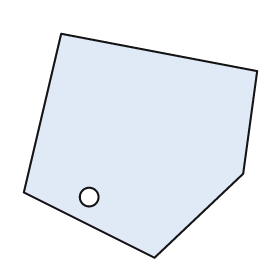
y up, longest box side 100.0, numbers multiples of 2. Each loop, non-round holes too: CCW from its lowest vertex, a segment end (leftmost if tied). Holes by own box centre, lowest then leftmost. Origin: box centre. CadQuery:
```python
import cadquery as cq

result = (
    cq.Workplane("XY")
    .moveTo(6.0, -48.0)
    .lineTo(44.0, -12.0)
    .lineTo(50.0, 32.0)
    .lineTo(-34.0, 48.0)
    .lineTo(-50.0, -20.0)
    .close()
    .moveTo(-22.0, -22.0)
    .circle(4.0)
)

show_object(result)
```